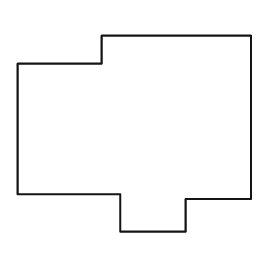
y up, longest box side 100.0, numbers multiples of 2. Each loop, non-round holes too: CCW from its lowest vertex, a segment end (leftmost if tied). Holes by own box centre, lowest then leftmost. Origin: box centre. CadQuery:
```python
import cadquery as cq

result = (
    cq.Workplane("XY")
    .moveTo(-6.0, -42.0)
    .lineTo(22.0, -42.0)
    .lineTo(22.0, -28.0)
    .lineTo(50.0, -28.0)
    .lineTo(50.0, 42.0)
    .lineTo(-14.0, 42.0)
    .lineTo(-14.0, 30.0)
    .lineTo(-50.0, 30.0)
    .lineTo(-50.0, -26.0)
    .lineTo(-6.0, -26.0)
    .close()
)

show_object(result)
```